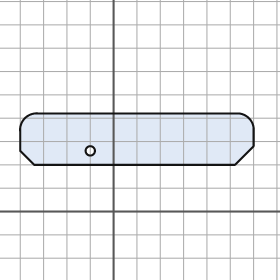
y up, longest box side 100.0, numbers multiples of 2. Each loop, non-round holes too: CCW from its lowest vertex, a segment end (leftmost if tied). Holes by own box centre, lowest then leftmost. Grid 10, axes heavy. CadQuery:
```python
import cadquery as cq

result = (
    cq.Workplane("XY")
    .moveTo(-34.0, 20.0)
    .lineTo(52.0, 20.0)
    .lineTo(60.0, 28.0)
    .lineTo(60.0, 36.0)
    .threePointArc((58.0, 40.0), (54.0, 42.0))
    .lineTo(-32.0, 42.0)
    .threePointArc((-38.0, 40.0), (-40.0, 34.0))
    .lineTo(-40.0, 26.0)
    .close()
    .moveTo(-10.0, 26.0)
    .circle(2.0)
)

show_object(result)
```